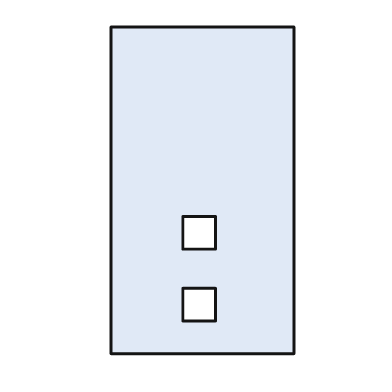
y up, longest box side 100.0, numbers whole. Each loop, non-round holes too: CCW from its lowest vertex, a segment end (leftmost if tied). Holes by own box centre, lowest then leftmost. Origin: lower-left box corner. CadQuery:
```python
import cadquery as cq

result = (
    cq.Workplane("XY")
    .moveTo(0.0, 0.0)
    .lineTo(56.0, 0.0)
    .lineTo(56.0, 100.0)
    .lineTo(0.0, 100.0)
    .close()
    .moveTo(22.0, 10.0)
    .lineTo(32.0, 10.0)
    .lineTo(32.0, 20.0)
    .lineTo(22.0, 20.0)
    .close()
    .moveTo(22.0, 32.0)
    .lineTo(32.0, 32.0)
    .lineTo(32.0, 42.0)
    .lineTo(22.0, 42.0)
    .close()
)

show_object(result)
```